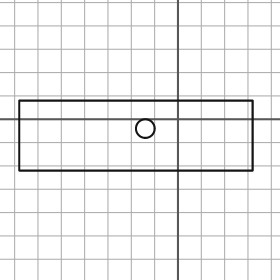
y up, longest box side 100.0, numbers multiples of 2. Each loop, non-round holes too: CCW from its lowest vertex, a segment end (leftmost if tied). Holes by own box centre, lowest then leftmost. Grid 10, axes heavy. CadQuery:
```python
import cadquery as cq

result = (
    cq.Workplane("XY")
    .moveTo(-68.0, -22.0)
    .lineTo(32.0, -22.0)
    .lineTo(32.0, 8.0)
    .lineTo(-68.0, 8.0)
    .close()
    .moveTo(-14.0, -4.0)
    .circle(4.0)
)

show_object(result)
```